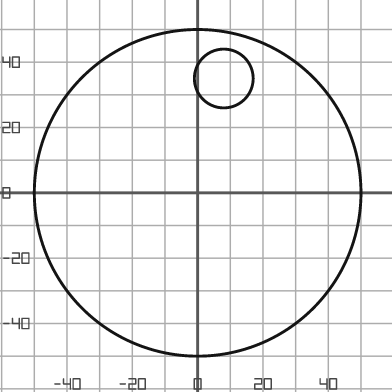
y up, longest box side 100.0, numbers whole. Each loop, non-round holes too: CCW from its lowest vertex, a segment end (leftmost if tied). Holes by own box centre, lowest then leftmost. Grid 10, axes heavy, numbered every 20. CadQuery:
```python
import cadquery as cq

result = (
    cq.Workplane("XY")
    .moveTo(0.0, 0.0)
    .circle(50.0)
    .moveTo(8.0, 35.0)
    .circle(9.0)
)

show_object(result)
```